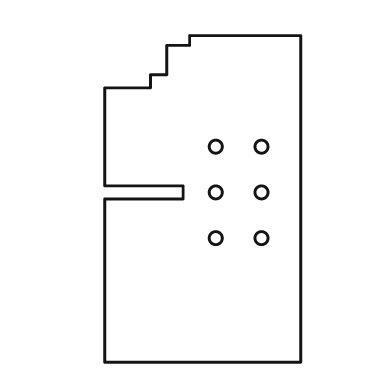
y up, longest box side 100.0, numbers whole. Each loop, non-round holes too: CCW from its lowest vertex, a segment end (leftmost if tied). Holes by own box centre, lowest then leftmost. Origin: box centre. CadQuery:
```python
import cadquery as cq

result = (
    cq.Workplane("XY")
    .moveTo(-30.0, -50.0)
    .lineTo(30.0, -50.0)
    .lineTo(30.0, 50.0)
    .lineTo(-4.0, 50.0)
    .lineTo(-4.0, 47.0)
    .lineTo(-11.0, 47.0)
    .lineTo(-11.0, 38.0)
    .lineTo(-16.0, 38.0)
    .lineTo(-16.0, 34.0)
    .lineTo(-30.0, 34.0)
    .lineTo(-30.0, 4.0)
    .lineTo(-6.0, 4.0)
    .lineTo(-6.0, 0.0)
    .lineTo(-30.0, 0.0)
    .close()
    .moveTo(4.0, -12.0)
    .circle(2.0)
    .moveTo(18.0, -12.0)
    .circle(2.0)
    .moveTo(4.0, 2.0)
    .circle(2.0)
    .moveTo(18.0, 2.0)
    .circle(2.0)
    .moveTo(4.0, 16.0)
    .circle(2.0)
    .moveTo(18.0, 16.0)
    .circle(2.0)
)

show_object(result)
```